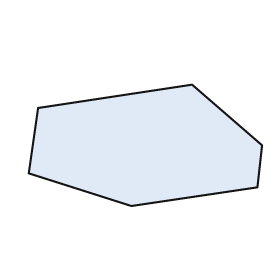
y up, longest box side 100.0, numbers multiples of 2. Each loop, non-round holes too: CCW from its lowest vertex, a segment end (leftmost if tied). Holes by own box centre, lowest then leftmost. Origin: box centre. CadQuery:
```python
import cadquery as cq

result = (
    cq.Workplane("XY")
    .moveTo(-6.0, -26.0)
    .lineTo(48.0, -18.0)
    .lineTo(50.0, 0.0)
    .lineTo(20.0, 26.0)
    .lineTo(-46.0, 16.0)
    .lineTo(-50.0, -12.0)
    .close()
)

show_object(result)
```